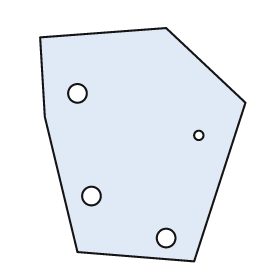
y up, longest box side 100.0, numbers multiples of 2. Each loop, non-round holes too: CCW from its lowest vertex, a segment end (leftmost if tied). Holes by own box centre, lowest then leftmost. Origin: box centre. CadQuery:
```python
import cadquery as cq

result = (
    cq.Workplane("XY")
    .moveTo(22.0, -50.0)
    .lineTo(44.0, 18.0)
    .lineTo(10.0, 50.0)
    .lineTo(-44.0, 46.0)
    .lineTo(-42.0, 12.0)
    .lineTo(-28.0, -46.0)
    .close()
    .moveTo(10.0, -40.0)
    .circle(4.0)
    .moveTo(-22.0, -22.0)
    .circle(4.0)
    .moveTo(24.0, 4.0)
    .circle(2.0)
    .moveTo(-28.0, 22.0)
    .circle(4.0)
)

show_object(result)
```